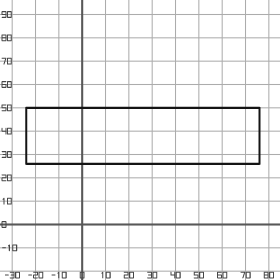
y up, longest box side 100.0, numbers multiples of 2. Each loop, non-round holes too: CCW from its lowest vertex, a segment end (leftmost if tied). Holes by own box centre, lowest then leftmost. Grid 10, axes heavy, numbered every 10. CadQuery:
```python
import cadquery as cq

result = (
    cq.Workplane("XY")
    .moveTo(-24.0, 26.0)
    .lineTo(76.0, 26.0)
    .lineTo(76.0, 50.0)
    .lineTo(-24.0, 50.0)
    .close()
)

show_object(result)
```